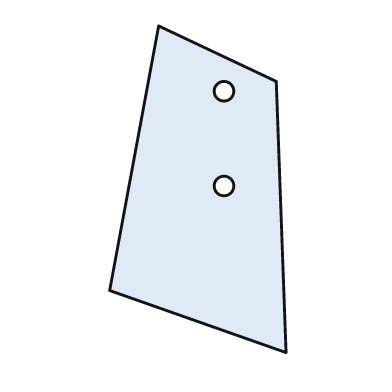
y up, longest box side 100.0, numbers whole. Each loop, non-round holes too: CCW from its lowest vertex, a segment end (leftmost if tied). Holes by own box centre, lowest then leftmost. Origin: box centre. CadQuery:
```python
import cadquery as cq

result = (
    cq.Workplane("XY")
    .moveTo(27.0, -50.0)
    .lineTo(24.0, 33.0)
    .lineTo(-12.0, 50.0)
    .lineTo(-27.0, -31.0)
    .close()
    .moveTo(8.0, 1.0)
    .circle(3.0)
    .moveTo(8.0, 30.0)
    .circle(3.0)
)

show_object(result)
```